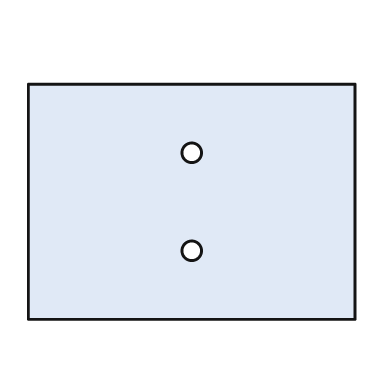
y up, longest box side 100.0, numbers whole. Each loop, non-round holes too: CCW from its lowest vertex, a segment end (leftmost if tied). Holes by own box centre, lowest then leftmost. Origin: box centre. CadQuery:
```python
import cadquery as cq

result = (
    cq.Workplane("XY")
    .moveTo(-50.0, -36.0)
    .lineTo(50.0, -36.0)
    .lineTo(50.0, 36.0)
    .lineTo(-50.0, 36.0)
    .close()
    .moveTo(0.0, -15.0)
    .circle(3.0)
    .moveTo(0.0, 15.0)
    .circle(3.0)
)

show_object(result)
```